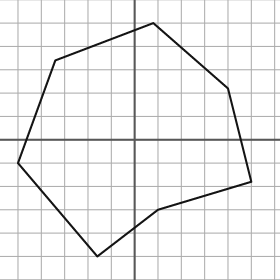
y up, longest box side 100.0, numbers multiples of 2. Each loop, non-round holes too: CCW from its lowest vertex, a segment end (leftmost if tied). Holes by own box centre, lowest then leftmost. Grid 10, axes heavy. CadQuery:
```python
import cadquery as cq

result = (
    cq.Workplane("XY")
    .moveTo(-16.0, -50.0)
    .lineTo(10.0, -30.0)
    .lineTo(50.0, -18.0)
    .lineTo(40.0, 22.0)
    .lineTo(8.0, 50.0)
    .lineTo(-34.0, 34.0)
    .lineTo(-50.0, -10.0)
    .close()
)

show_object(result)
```